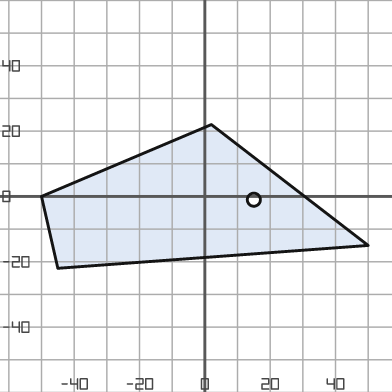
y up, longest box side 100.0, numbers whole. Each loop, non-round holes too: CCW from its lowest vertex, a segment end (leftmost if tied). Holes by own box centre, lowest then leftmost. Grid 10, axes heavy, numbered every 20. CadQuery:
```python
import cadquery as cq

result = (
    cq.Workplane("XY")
    .moveTo(-45.0, -22.0)
    .lineTo(50.0, -15.0)
    .lineTo(2.0, 22.0)
    .lineTo(-50.0, 0.0)
    .close()
    .moveTo(15.0, -1.0)
    .circle(2.0)
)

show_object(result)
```